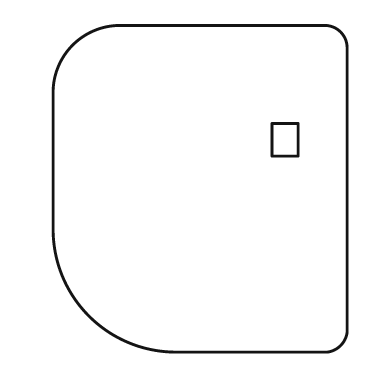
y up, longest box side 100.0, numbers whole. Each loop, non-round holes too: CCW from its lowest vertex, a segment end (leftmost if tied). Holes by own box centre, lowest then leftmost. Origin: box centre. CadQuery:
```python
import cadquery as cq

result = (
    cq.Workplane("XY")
    .moveTo(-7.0, -50.0)
    .lineTo(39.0, -50.0)
    .threePointArc((43.0, -48.0), (45.0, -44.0))
    .lineTo(45.0, 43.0)
    .threePointArc((43.0, 48.0), (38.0, 50.0))
    .lineTo(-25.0, 50.0)
    .threePointArc((-39.0, 44.0), (-45.0, 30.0))
    .lineTo(-45.0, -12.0)
    .threePointArc((-34.0, -39.0), (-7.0, -50.0))
    .close()
    .moveTo(22.0, 10.0)
    .lineTo(30.0, 10.0)
    .lineTo(30.0, 20.0)
    .lineTo(22.0, 20.0)
    .close()
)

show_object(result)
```